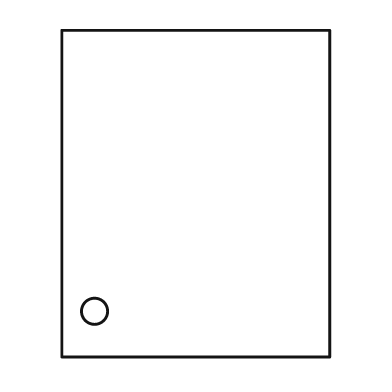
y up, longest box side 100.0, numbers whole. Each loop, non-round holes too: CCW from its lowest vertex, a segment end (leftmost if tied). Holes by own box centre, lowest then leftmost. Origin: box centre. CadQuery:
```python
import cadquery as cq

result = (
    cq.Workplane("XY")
    .moveTo(-41.0, -50.0)
    .lineTo(41.0, -50.0)
    .lineTo(41.0, 50.0)
    .lineTo(-41.0, 50.0)
    .close()
    .moveTo(-31.0, -36.0)
    .circle(4.0)
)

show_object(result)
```